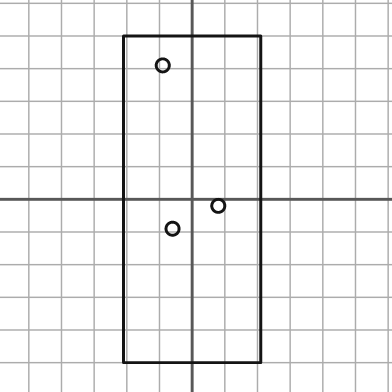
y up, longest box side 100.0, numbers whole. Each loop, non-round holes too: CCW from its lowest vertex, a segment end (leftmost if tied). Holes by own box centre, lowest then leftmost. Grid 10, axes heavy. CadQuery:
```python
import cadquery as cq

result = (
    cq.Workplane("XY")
    .moveTo(-21.0, -50.0)
    .lineTo(21.0, -50.0)
    .lineTo(21.0, 50.0)
    .lineTo(-21.0, 50.0)
    .close()
    .moveTo(-6.0, -9.0)
    .circle(2.0)
    .moveTo(8.0, -2.0)
    .circle(2.0)
    .moveTo(-9.0, 41.0)
    .circle(2.0)
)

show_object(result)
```